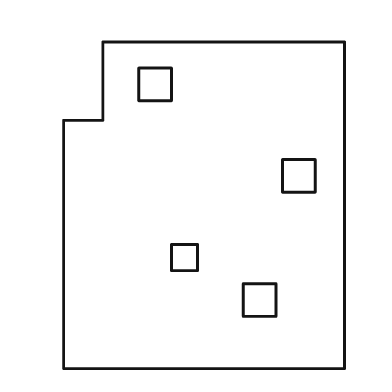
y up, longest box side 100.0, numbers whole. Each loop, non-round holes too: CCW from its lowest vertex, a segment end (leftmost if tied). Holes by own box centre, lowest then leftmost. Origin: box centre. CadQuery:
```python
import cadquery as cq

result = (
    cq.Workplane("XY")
    .moveTo(-43.0, -50.0)
    .lineTo(43.0, -50.0)
    .lineTo(43.0, 50.0)
    .lineTo(-31.0, 50.0)
    .lineTo(-31.0, 26.0)
    .lineTo(-43.0, 26.0)
    .close()
    .moveTo(12.0, -34.0)
    .lineTo(22.0, -34.0)
    .lineTo(22.0, -24.0)
    .lineTo(12.0, -24.0)
    .close()
    .moveTo(-10.0, -20.0)
    .lineTo(-2.0, -20.0)
    .lineTo(-2.0, -12.0)
    .lineTo(-10.0, -12.0)
    .close()
    .moveTo(24.0, 4.0)
    .lineTo(34.0, 4.0)
    .lineTo(34.0, 14.0)
    .lineTo(24.0, 14.0)
    .close()
    .moveTo(-20.0, 32.0)
    .lineTo(-10.0, 32.0)
    .lineTo(-10.0, 42.0)
    .lineTo(-20.0, 42.0)
    .close()
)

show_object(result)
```